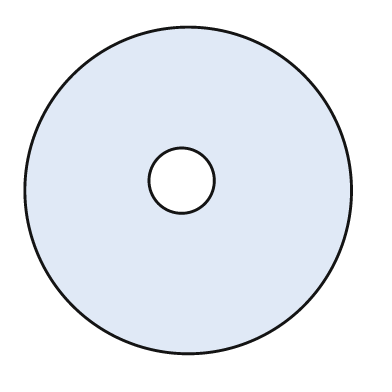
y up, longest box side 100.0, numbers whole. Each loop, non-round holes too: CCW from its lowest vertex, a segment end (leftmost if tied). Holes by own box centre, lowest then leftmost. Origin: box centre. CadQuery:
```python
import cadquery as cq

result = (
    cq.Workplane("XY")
    .moveTo(0.0, 0.0)
    .circle(50.0)
    .moveTo(-2.0, 3.0)
    .circle(10.0)
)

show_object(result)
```